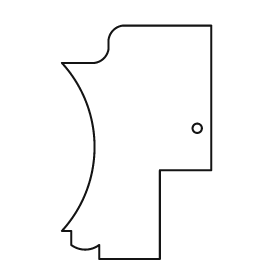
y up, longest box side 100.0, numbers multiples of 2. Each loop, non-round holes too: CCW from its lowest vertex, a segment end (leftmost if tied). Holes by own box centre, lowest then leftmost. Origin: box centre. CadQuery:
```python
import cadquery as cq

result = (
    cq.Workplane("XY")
    .moveTo(-16.0, -50.0)
    .lineTo(10.0, -50.0)
    .lineTo(10.0, -12.0)
    .lineTo(32.0, -12.0)
    .lineTo(32.0, 50.0)
    .lineTo(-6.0, 50.0)
    .threePointArc((-10.0, 48.0), (-12.0, 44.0))
    .lineTo(-12.0, 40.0)
    .threePointArc((-14.0, 36.0), (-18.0, 34.0))
    .lineTo(-32.0, 34.0)
    .threePointArc((-18.0, -2.0), (-32.0, -38.0))
    .lineTo(-28.0, -38.0)
    .lineTo(-28.0, -44.0)
    .threePointArc((-22.0, -46.0), (-16.0, -44.0))
    .close()
    .moveTo(26.0, 6.0)
    .circle(2.0)
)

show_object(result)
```